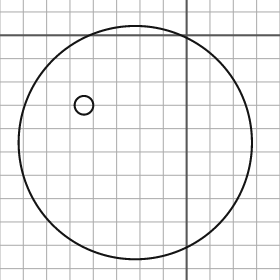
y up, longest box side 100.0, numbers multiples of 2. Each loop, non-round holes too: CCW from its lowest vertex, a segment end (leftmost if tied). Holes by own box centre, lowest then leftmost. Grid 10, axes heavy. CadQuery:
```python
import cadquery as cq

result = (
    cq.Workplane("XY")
    .moveTo(-22.0, -46.0)
    .circle(50.0)
    .moveTo(-44.0, -30.0)
    .circle(4.0)
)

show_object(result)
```